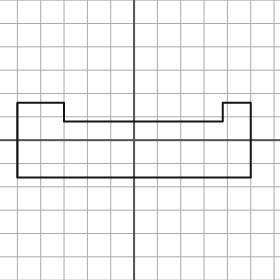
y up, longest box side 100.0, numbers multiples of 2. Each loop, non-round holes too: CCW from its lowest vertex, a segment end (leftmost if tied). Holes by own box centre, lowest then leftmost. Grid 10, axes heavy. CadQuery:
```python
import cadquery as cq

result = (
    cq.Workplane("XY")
    .moveTo(-50.0, -16.0)
    .lineTo(50.0, -16.0)
    .lineTo(50.0, 16.0)
    .lineTo(38.0, 16.0)
    .lineTo(38.0, 8.0)
    .lineTo(-30.0, 8.0)
    .lineTo(-30.0, 16.0)
    .lineTo(-50.0, 16.0)
    .close()
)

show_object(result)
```